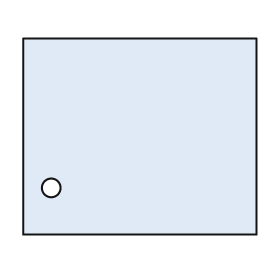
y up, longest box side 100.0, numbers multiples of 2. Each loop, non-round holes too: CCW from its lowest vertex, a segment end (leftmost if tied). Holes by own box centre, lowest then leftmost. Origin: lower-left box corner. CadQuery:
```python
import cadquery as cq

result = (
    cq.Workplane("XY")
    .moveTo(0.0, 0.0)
    .lineTo(100.0, 0.0)
    .lineTo(100.0, 84.0)
    .lineTo(0.0, 84.0)
    .close()
    .moveTo(12.0, 20.0)
    .circle(4.0)
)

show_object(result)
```